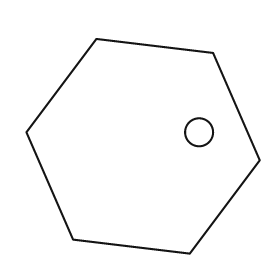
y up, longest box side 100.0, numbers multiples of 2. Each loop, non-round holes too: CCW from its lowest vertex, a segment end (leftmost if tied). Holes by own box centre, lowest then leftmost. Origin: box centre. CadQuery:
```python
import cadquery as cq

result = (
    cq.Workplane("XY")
    .moveTo(20.0, -46.0)
    .lineTo(50.0, -6.0)
    .lineTo(30.0, 40.0)
    .lineTo(-20.0, 46.0)
    .lineTo(-50.0, 6.0)
    .lineTo(-30.0, -40.0)
    .close()
    .moveTo(24.0, 6.0)
    .circle(6.0)
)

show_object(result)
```